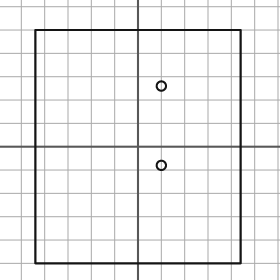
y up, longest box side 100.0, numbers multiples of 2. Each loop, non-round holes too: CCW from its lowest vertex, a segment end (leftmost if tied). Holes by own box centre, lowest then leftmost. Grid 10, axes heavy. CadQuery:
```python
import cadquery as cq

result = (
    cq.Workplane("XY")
    .moveTo(-44.0, -50.0)
    .lineTo(44.0, -50.0)
    .lineTo(44.0, 50.0)
    .lineTo(-44.0, 50.0)
    .close()
    .moveTo(10.0, -8.0)
    .circle(2.0)
    .moveTo(10.0, 26.0)
    .circle(2.0)
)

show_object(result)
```